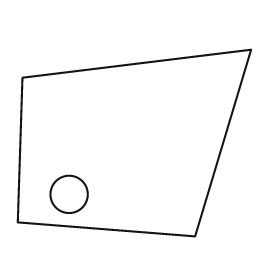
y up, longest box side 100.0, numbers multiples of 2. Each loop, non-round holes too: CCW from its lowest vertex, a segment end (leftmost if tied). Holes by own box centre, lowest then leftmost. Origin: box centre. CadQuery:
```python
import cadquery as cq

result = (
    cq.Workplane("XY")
    .moveTo(26.0, -40.0)
    .lineTo(50.0, 40.0)
    .lineTo(-48.0, 28.0)
    .lineTo(-50.0, -34.0)
    .close()
    .moveTo(-28.0, -22.0)
    .circle(8.0)
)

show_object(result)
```